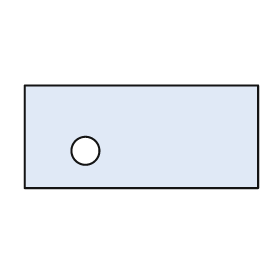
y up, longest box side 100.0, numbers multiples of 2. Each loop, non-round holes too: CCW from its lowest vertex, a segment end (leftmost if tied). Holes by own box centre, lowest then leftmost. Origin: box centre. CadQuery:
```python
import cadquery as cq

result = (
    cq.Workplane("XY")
    .moveTo(-50.0, -22.0)
    .lineTo(50.0, -22.0)
    .lineTo(50.0, 22.0)
    .lineTo(-50.0, 22.0)
    .close()
    .moveTo(-24.0, -6.0)
    .circle(6.0)
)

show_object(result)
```